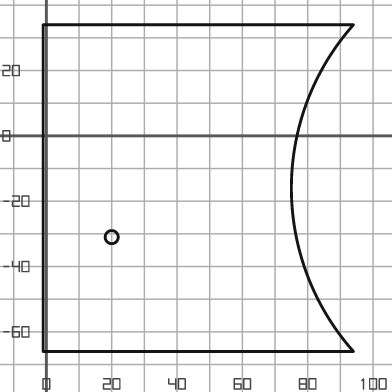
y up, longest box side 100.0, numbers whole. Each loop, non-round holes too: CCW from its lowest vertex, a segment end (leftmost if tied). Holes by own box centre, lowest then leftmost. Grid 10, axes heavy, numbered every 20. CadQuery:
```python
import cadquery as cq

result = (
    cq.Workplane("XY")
    .moveTo(-1.0, -66.0)
    .lineTo(94.0, -66.0)
    .threePointArc((75.0, -16.0), (94.0, 34.0))
    .lineTo(-1.0, 34.0)
    .close()
    .moveTo(20.0, -31.0)
    .circle(2.0)
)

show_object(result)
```